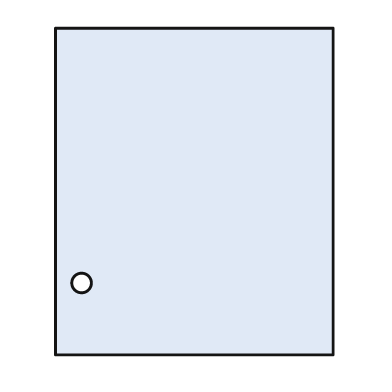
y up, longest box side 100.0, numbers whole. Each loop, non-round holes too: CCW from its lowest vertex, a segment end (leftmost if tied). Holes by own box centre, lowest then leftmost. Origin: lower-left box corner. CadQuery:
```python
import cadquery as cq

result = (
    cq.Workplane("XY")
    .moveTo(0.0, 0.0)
    .lineTo(85.0, 0.0)
    .lineTo(85.0, 100.0)
    .lineTo(0.0, 100.0)
    .close()
    .moveTo(8.0, 22.0)
    .circle(3.0)
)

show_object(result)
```